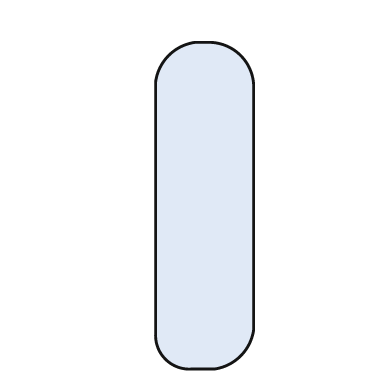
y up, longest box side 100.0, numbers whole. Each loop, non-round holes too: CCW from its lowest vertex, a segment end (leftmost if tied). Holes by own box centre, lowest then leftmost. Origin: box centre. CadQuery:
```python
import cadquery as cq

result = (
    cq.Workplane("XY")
    .moveTo(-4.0, -50.0)
    .lineTo(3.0, -50.0)
    .threePointArc((11.0, -46.0), (15.0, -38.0))
    .lineTo(15.0, 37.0)
    .threePointArc((11.0, 46.0), (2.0, 50.0))
    .lineTo(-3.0, 50.0)
    .threePointArc((-11.0, 46.0), (-15.0, 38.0))
    .lineTo(-15.0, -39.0)
    .threePointArc((-12.0, -47.0), (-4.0, -50.0))
    .close()
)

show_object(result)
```